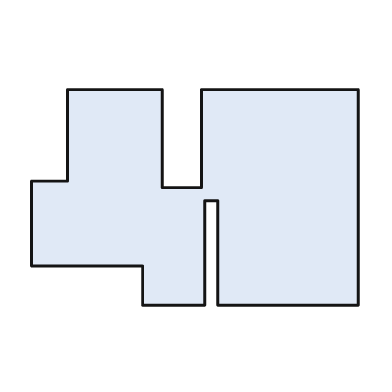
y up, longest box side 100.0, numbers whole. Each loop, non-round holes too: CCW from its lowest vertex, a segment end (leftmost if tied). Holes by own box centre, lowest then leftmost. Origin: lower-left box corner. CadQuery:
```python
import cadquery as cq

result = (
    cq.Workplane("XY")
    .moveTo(34.0, 0.0)
    .lineTo(53.0, 0.0)
    .lineTo(53.0, 32.0)
    .lineTo(57.0, 32.0)
    .lineTo(57.0, 0.0)
    .lineTo(100.0, 0.0)
    .lineTo(100.0, 66.0)
    .lineTo(52.0, 66.0)
    .lineTo(52.0, 36.0)
    .lineTo(40.0, 36.0)
    .lineTo(40.0, 66.0)
    .lineTo(11.0, 66.0)
    .lineTo(11.0, 38.0)
    .lineTo(0.0, 38.0)
    .lineTo(0.0, 12.0)
    .lineTo(34.0, 12.0)
    .close()
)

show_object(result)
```